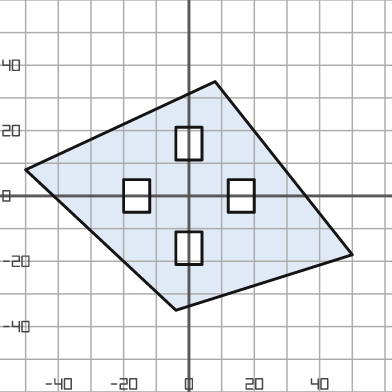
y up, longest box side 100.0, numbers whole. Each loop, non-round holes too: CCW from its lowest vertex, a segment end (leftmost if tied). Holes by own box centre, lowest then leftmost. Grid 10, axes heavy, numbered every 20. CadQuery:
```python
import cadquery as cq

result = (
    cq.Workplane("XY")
    .moveTo(-4.0, -35.0)
    .lineTo(50.0, -18.0)
    .lineTo(8.0, 35.0)
    .lineTo(-50.0, 8.0)
    .close()
    .moveTo(-4.0, -21.0)
    .lineTo(4.0, -21.0)
    .lineTo(4.0, -11.0)
    .lineTo(-4.0, -11.0)
    .close()
    .moveTo(-20.0, -5.0)
    .lineTo(-12.0, -5.0)
    .lineTo(-12.0, 5.0)
    .lineTo(-20.0, 5.0)
    .close()
    .moveTo(12.0, -5.0)
    .lineTo(20.0, -5.0)
    .lineTo(20.0, 5.0)
    .lineTo(12.0, 5.0)
    .close()
    .moveTo(-4.0, 11.0)
    .lineTo(4.0, 11.0)
    .lineTo(4.0, 21.0)
    .lineTo(-4.0, 21.0)
    .close()
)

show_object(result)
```